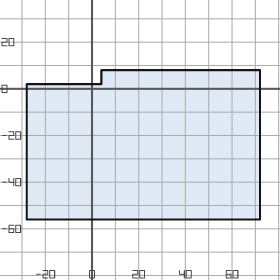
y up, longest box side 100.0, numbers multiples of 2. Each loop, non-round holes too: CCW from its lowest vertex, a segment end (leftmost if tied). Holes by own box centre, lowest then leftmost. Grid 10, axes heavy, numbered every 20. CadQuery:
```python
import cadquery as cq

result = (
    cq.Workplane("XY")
    .moveTo(-28.0, -56.0)
    .lineTo(72.0, -56.0)
    .lineTo(72.0, 8.0)
    .lineTo(4.0, 8.0)
    .lineTo(4.0, 2.0)
    .lineTo(-28.0, 2.0)
    .close()
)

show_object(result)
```